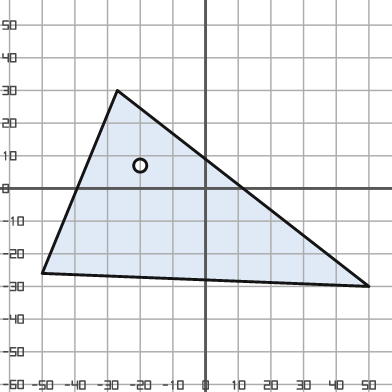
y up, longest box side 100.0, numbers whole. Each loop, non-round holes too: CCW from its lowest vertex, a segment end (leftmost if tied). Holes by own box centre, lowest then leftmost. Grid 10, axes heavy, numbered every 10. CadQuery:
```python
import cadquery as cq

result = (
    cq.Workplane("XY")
    .moveTo(50.0, -30.0)
    .lineTo(-27.0, 30.0)
    .lineTo(-50.0, -26.0)
    .close()
    .moveTo(-20.0, 7.0)
    .circle(2.0)
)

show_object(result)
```